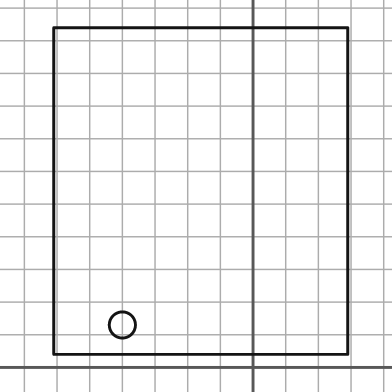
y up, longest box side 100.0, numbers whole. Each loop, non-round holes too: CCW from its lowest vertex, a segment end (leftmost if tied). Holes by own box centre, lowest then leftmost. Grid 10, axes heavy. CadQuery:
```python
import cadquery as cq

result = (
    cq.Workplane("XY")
    .moveTo(-61.0, 4.0)
    .lineTo(29.0, 4.0)
    .lineTo(29.0, 104.0)
    .lineTo(-61.0, 104.0)
    .close()
    .moveTo(-40.0, 13.0)
    .circle(4.0)
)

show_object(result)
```